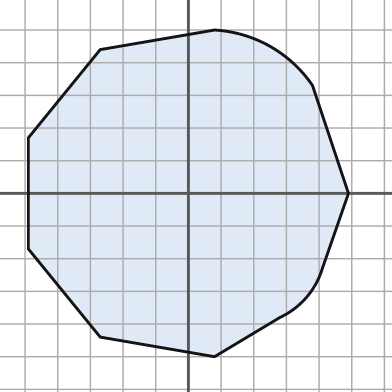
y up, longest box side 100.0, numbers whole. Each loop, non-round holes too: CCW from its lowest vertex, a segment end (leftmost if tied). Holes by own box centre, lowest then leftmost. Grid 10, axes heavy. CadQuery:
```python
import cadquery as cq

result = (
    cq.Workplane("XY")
    .moveTo(8.0, -50.0)
    .lineTo(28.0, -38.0)
    .threePointArc((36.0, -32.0), (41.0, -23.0))
    .lineTo(49.0, 0.0)
    .lineTo(38.0, 33.0)
    .threePointArc((25.0, 45.0), (8.0, 50.0))
    .lineTo(-27.0, 44.0)
    .lineTo(-49.0, 17.0)
    .lineTo(-49.0, -17.0)
    .lineTo(-27.0, -44.0)
    .close()
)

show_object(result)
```